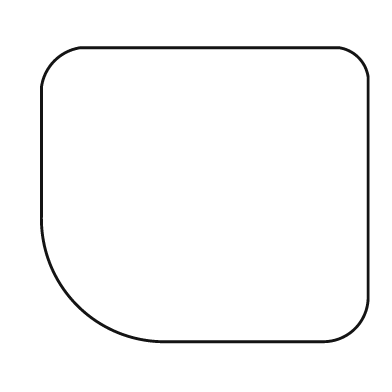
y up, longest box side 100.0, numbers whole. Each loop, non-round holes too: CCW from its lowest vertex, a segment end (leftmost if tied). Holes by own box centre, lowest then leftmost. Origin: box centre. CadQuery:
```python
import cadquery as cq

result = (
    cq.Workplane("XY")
    .moveTo(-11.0, -45.0)
    .lineTo(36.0, -45.0)
    .threePointArc((46.0, -41.0), (50.0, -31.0))
    .lineTo(50.0, 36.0)
    .threePointArc((47.0, 42.0), (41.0, 45.0))
    .lineTo(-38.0, 45.0)
    .threePointArc((-46.0, 41.0), (-50.0, 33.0))
    .lineTo(-50.0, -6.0)
    .threePointArc((-39.0, -34.0), (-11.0, -45.0))
    .close()
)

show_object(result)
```